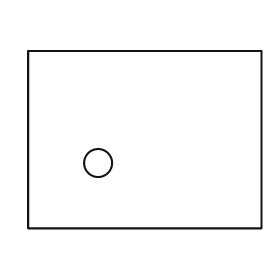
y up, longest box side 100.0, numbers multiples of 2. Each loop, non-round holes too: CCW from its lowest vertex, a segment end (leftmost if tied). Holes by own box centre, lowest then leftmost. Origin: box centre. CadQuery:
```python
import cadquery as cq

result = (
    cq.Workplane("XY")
    .moveTo(-50.0, -38.0)
    .lineTo(50.0, -38.0)
    .lineTo(50.0, 38.0)
    .lineTo(-50.0, 38.0)
    .close()
    .moveTo(-20.0, -10.0)
    .circle(6.0)
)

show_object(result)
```